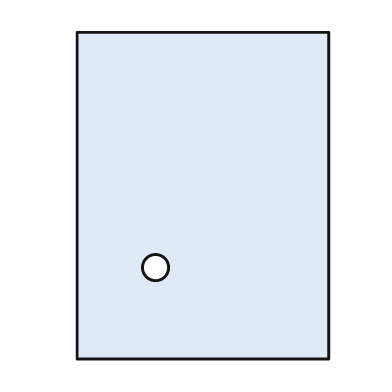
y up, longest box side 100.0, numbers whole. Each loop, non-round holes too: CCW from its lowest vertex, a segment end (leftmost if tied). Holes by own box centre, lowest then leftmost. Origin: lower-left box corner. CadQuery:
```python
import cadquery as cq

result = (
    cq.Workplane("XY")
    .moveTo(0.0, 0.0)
    .lineTo(77.0, 0.0)
    .lineTo(77.0, 100.0)
    .lineTo(0.0, 100.0)
    .close()
    .moveTo(24.0, 28.0)
    .circle(4.0)
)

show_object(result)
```